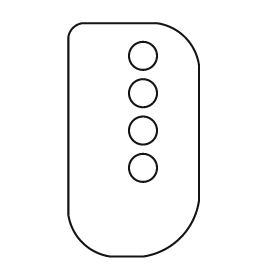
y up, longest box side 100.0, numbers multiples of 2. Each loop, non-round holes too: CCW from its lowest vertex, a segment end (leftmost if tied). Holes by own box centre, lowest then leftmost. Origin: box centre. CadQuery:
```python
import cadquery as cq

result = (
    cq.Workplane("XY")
    .moveTo(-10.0, -50.0)
    .lineTo(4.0, -50.0)
    .threePointArc((20.0, -42.0), (28.0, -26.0))
    .lineTo(28.0, 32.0)
    .threePointArc((22.0, 44.0), (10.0, 50.0))
    .lineTo(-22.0, 50.0)
    .threePointArc((-26.0, 48.0), (-28.0, 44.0))
    .lineTo(-28.0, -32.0)
    .threePointArc((-22.0, -44.0), (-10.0, -50.0))
    .close()
    .moveTo(4.0, -12.0)
    .circle(6.0)
    .moveTo(4.0, 4.0)
    .circle(6.0)
    .moveTo(4.0, 20.0)
    .circle(6.0)
    .moveTo(4.0, 36.0)
    .circle(6.0)
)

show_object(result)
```